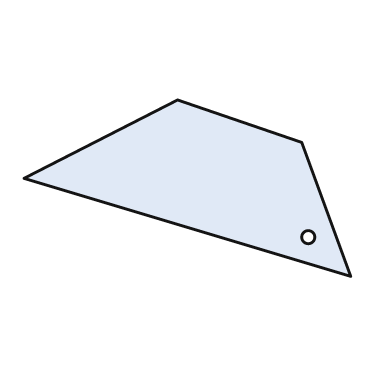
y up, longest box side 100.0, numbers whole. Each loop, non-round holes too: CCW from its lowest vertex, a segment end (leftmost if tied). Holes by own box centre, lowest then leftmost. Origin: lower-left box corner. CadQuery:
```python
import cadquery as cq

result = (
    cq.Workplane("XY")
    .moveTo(100.0, 0.0)
    .lineTo(85.0, 41.0)
    .lineTo(47.0, 54.0)
    .lineTo(0.0, 30.0)
    .close()
    .moveTo(87.0, 12.0)
    .circle(2.0)
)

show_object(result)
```